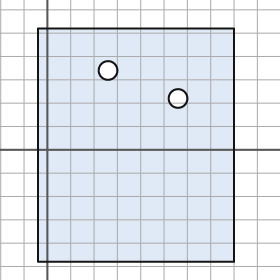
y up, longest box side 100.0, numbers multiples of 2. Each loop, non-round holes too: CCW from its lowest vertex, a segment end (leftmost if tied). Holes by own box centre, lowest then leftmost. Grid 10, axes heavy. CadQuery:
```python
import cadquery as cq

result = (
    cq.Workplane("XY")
    .moveTo(-4.0, -48.0)
    .lineTo(80.0, -48.0)
    .lineTo(80.0, 52.0)
    .lineTo(-4.0, 52.0)
    .close()
    .moveTo(56.0, 22.0)
    .circle(4.0)
    .moveTo(26.0, 34.0)
    .circle(4.0)
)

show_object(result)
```